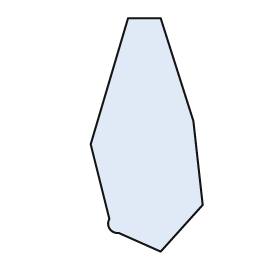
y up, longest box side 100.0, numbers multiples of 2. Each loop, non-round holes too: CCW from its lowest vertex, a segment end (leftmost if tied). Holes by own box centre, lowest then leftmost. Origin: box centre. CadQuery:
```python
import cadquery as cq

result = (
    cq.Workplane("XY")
    .moveTo(6.0, -50.0)
    .lineTo(24.0, -30.0)
    .lineTo(20.0, 6.0)
    .lineTo(6.0, 50.0)
    .lineTo(-8.0, 50.0)
    .lineTo(-24.0, -4.0)
    .lineTo(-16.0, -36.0)
    .threePointArc((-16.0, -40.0), (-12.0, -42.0))
    .close()
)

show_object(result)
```